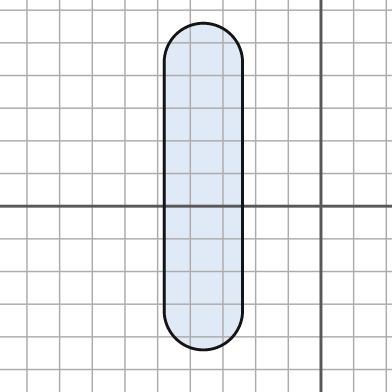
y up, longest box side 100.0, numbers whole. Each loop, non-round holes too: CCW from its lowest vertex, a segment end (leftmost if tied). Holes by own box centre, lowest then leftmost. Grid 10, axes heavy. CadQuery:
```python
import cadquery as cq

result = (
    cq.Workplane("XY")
    .moveTo(-48.0, -32.0)
    .threePointArc((-36.0, -44.0), (-24.0, -32.0))
    .lineTo(-24.0, 44.0)
    .threePointArc((-36.0, 56.0), (-48.0, 44.0))
    .close()
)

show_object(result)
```